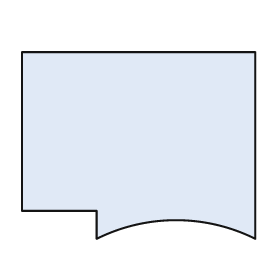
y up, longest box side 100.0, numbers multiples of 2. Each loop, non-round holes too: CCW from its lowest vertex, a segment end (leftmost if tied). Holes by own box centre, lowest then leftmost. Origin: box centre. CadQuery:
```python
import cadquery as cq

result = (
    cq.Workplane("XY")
    .moveTo(-18.0, -40.0)
    .threePointArc((16.0, -32.0), (50.0, -40.0))
    .lineTo(50.0, 40.0)
    .lineTo(-50.0, 40.0)
    .lineTo(-50.0, -28.0)
    .lineTo(-18.0, -28.0)
    .close()
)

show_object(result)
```